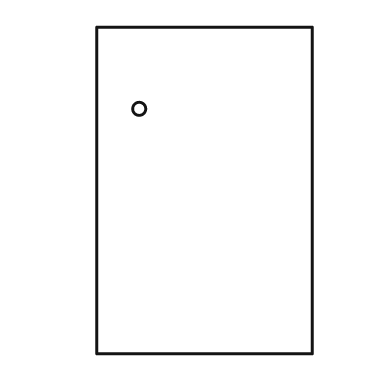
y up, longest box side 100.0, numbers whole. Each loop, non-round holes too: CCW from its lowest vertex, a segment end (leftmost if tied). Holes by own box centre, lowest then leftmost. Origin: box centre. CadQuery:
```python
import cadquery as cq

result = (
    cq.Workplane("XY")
    .moveTo(-33.0, -50.0)
    .lineTo(33.0, -50.0)
    .lineTo(33.0, 50.0)
    .lineTo(-33.0, 50.0)
    .close()
    .moveTo(-20.0, 25.0)
    .circle(2.0)
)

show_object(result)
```